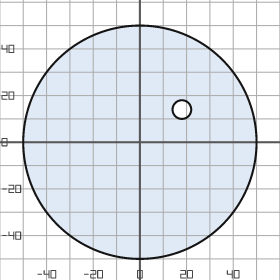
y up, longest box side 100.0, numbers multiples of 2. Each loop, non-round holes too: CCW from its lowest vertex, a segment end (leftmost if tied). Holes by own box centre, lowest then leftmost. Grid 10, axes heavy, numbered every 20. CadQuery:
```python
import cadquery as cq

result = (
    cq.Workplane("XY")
    .moveTo(0.0, 0.0)
    .circle(50.0)
    .moveTo(18.0, 14.0)
    .circle(4.0)
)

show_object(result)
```